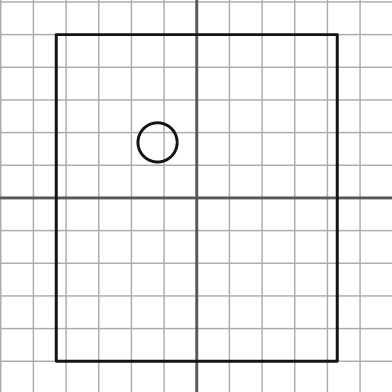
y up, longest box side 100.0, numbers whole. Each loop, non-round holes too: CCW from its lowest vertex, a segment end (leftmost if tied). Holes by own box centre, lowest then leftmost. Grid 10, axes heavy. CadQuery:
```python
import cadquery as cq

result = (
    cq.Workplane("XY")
    .moveTo(-43.0, -50.0)
    .lineTo(43.0, -50.0)
    .lineTo(43.0, 50.0)
    .lineTo(-43.0, 50.0)
    .close()
    .moveTo(-12.0, 17.0)
    .circle(6.0)
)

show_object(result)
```